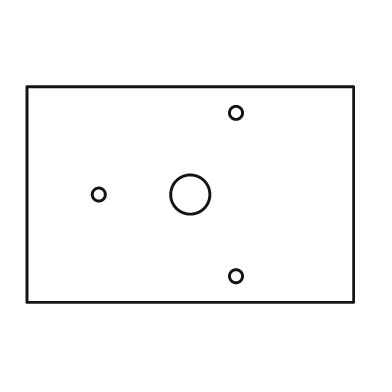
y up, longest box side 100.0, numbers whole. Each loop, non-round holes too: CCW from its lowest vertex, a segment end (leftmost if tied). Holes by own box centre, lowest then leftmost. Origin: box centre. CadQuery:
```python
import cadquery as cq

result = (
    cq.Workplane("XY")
    .moveTo(-50.0, -33.0)
    .lineTo(50.0, -33.0)
    .lineTo(50.0, 33.0)
    .lineTo(-50.0, 33.0)
    .close()
    .moveTo(14.0, -25.0)
    .circle(2.0)
    .moveTo(-28.0, 0.0)
    .circle(2.0)
    .moveTo(0.0, 0.0)
    .circle(6.0)
    .moveTo(14.0, 25.0)
    .circle(2.0)
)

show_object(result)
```